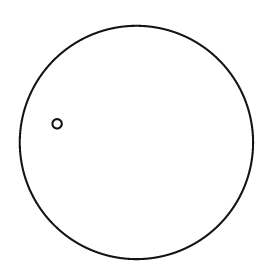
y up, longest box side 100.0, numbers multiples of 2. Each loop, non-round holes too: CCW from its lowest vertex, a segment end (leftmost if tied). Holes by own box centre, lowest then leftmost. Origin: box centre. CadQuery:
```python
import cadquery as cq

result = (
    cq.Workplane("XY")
    .moveTo(0.0, 0.0)
    .circle(50.0)
    .moveTo(-34.0, 8.0)
    .circle(2.0)
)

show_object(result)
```